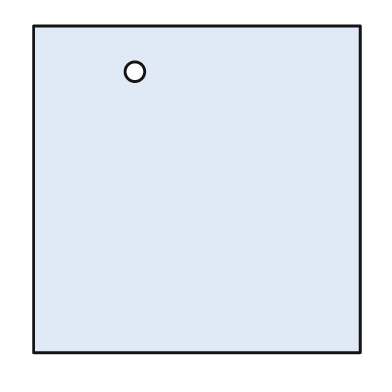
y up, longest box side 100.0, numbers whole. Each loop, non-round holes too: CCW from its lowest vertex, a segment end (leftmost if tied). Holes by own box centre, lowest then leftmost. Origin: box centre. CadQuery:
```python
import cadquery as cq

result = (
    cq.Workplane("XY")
    .moveTo(-50.0, -50.0)
    .lineTo(50.0, -50.0)
    .lineTo(50.0, 50.0)
    .lineTo(-50.0, 50.0)
    .close()
    .moveTo(-19.0, 36.0)
    .circle(3.0)
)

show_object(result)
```